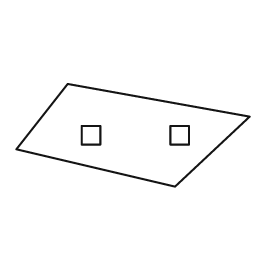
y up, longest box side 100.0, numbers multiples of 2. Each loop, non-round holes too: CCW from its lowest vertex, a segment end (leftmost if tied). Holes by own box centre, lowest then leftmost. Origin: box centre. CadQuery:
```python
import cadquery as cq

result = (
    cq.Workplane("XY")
    .moveTo(18.0, -22.0)
    .lineTo(50.0, 8.0)
    .lineTo(-28.0, 22.0)
    .lineTo(-50.0, -6.0)
    .close()
    .moveTo(-22.0, -4.0)
    .lineTo(-14.0, -4.0)
    .lineTo(-14.0, 4.0)
    .lineTo(-22.0, 4.0)
    .close()
    .moveTo(16.0, -4.0)
    .lineTo(24.0, -4.0)
    .lineTo(24.0, 4.0)
    .lineTo(16.0, 4.0)
    .close()
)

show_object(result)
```